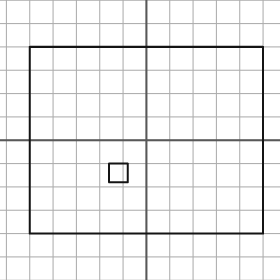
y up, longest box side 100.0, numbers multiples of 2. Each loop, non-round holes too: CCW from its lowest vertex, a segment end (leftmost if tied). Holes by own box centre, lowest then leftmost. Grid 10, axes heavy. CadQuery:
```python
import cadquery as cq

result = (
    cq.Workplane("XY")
    .moveTo(-50.0, -40.0)
    .lineTo(50.0, -40.0)
    .lineTo(50.0, 40.0)
    .lineTo(-50.0, 40.0)
    .close()
    .moveTo(-16.0, -18.0)
    .lineTo(-8.0, -18.0)
    .lineTo(-8.0, -10.0)
    .lineTo(-16.0, -10.0)
    .close()
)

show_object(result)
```